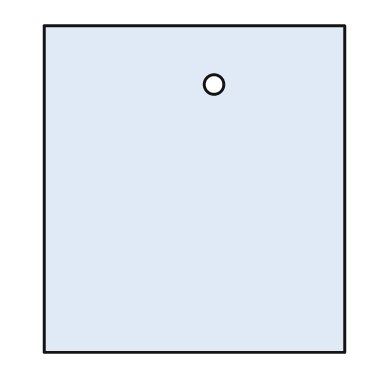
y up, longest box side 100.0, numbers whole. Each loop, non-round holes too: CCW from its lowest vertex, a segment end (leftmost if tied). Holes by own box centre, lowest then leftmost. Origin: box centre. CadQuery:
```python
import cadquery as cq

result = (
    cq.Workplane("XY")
    .moveTo(-46.0, -50.0)
    .lineTo(46.0, -50.0)
    .lineTo(46.0, 50.0)
    .lineTo(-46.0, 50.0)
    .close()
    .moveTo(6.0, 32.0)
    .circle(3.0)
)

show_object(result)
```